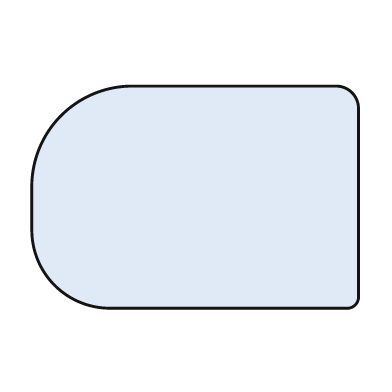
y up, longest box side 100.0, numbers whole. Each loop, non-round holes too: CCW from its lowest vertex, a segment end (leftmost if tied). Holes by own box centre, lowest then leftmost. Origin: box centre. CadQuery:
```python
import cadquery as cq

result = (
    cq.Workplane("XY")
    .moveTo(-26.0, -34.0)
    .lineTo(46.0, -34.0)
    .threePointArc((49.0, -33.0), (50.0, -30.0))
    .lineTo(50.0, 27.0)
    .threePointArc((48.0, 32.0), (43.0, 34.0))
    .lineTo(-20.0, 34.0)
    .threePointArc((-41.0, 25.0), (-50.0, 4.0))
    .lineTo(-50.0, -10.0)
    .threePointArc((-43.0, -27.0), (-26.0, -34.0))
    .close()
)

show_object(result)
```